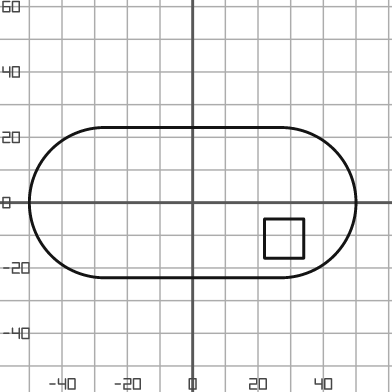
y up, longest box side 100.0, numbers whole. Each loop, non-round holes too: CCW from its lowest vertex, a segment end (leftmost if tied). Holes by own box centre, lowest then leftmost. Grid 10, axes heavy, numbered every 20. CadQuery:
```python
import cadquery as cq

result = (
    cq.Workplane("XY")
    .moveTo(-27.0, -23.0)
    .lineTo(27.0, -23.0)
    .threePointArc((50.0, 0.0), (27.0, 23.0))
    .lineTo(-27.0, 23.0)
    .threePointArc((-50.0, 0.0), (-27.0, -23.0))
    .close()
    .moveTo(22.0, -17.0)
    .lineTo(34.0, -17.0)
    .lineTo(34.0, -5.0)
    .lineTo(22.0, -5.0)
    .close()
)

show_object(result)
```